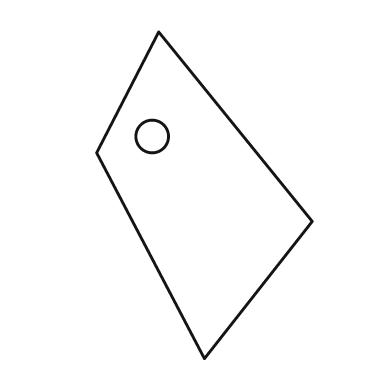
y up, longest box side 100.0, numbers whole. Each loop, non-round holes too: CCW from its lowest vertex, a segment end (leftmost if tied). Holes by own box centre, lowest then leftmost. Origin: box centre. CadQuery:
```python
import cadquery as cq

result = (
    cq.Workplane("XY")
    .moveTo(0.0, -50.0)
    .lineTo(33.0, -8.0)
    .lineTo(-14.0, 50.0)
    .lineTo(-33.0, 13.0)
    .close()
    .moveTo(-16.0, 18.0)
    .circle(5.0)
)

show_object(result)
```